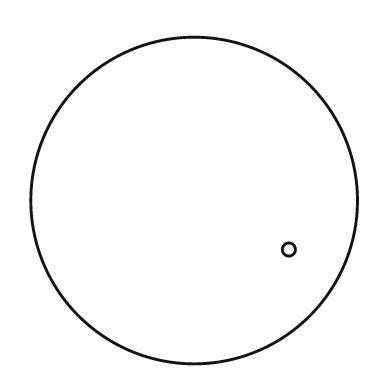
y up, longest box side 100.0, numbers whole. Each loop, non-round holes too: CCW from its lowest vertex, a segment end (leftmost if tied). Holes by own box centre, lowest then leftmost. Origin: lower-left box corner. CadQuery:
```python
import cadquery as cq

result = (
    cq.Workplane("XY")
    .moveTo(50.0, 50.0)
    .circle(50.0)
    .moveTo(79.0, 35.0)
    .circle(2.0)
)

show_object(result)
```